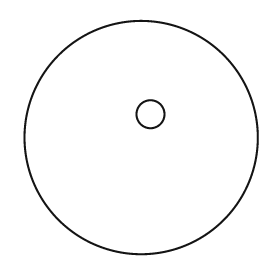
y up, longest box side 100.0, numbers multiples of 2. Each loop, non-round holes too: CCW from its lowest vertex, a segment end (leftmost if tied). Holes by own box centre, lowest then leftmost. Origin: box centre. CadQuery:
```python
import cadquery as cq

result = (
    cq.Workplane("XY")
    .moveTo(0.0, 0.0)
    .circle(50.0)
    .moveTo(4.0, 10.0)
    .circle(6.0)
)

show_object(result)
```